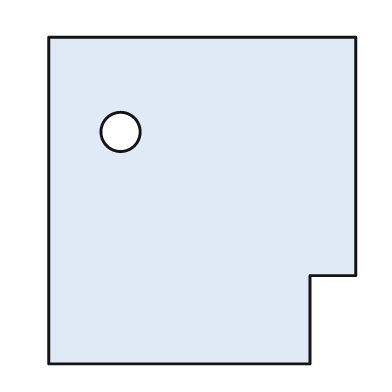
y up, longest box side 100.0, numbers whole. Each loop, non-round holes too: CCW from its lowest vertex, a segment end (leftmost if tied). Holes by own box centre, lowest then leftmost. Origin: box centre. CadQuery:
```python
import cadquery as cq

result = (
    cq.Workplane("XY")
    .moveTo(-47.0, -50.0)
    .lineTo(33.0, -50.0)
    .lineTo(33.0, -23.0)
    .lineTo(47.0, -23.0)
    .lineTo(47.0, 50.0)
    .lineTo(-47.0, 50.0)
    .close()
    .moveTo(-25.0, 21.0)
    .circle(6.0)
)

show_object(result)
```